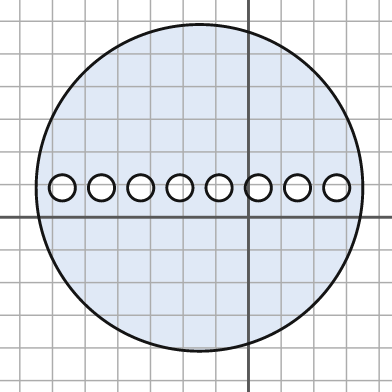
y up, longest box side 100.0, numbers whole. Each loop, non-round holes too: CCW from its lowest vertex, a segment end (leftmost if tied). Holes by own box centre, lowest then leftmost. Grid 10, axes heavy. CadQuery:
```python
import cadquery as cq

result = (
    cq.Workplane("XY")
    .moveTo(-15.0, 9.0)
    .circle(50.0)
    .moveTo(-57.0, 9.0)
    .circle(4.0)
    .moveTo(-45.0, 9.0)
    .circle(4.0)
    .moveTo(-33.0, 9.0)
    .circle(4.0)
    .moveTo(-21.0, 9.0)
    .circle(4.0)
    .moveTo(-9.0, 9.0)
    .circle(4.0)
    .moveTo(3.0, 9.0)
    .circle(4.0)
    .moveTo(15.0, 9.0)
    .circle(4.0)
    .moveTo(27.0, 9.0)
    .circle(4.0)
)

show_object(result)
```